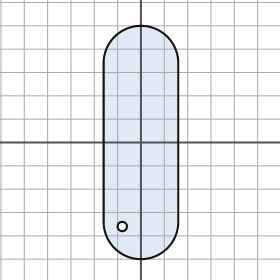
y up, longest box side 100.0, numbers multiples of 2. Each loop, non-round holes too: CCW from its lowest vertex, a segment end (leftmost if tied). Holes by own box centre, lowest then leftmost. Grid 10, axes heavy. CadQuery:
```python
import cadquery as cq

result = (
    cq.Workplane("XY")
    .moveTo(-16.0, -34.0)
    .threePointArc((0.0, -50.0), (16.0, -34.0))
    .lineTo(16.0, 34.0)
    .threePointArc((0.0, 50.0), (-16.0, 34.0))
    .close()
    .moveTo(-8.0, -36.0)
    .circle(2.0)
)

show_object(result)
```